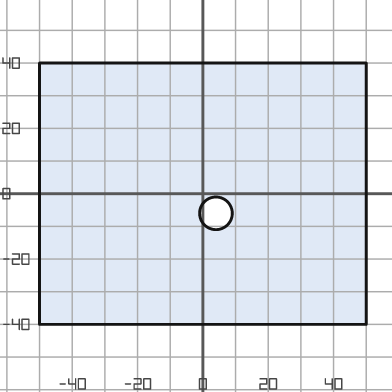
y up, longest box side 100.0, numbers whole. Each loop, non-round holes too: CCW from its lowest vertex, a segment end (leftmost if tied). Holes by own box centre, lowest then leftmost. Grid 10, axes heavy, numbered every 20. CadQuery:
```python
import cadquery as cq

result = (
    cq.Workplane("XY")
    .moveTo(-50.0, -40.0)
    .lineTo(50.0, -40.0)
    .lineTo(50.0, 40.0)
    .lineTo(-50.0, 40.0)
    .close()
    .moveTo(4.0, -6.0)
    .circle(5.0)
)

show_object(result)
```